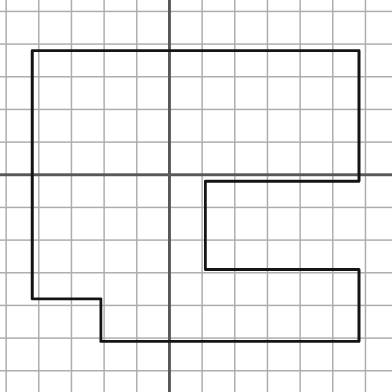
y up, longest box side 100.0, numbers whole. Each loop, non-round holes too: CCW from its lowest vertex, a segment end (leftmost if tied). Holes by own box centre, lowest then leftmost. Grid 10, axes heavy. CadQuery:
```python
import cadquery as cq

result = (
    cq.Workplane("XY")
    .moveTo(-21.0, -51.0)
    .lineTo(58.0, -51.0)
    .lineTo(58.0, -29.0)
    .lineTo(11.0, -29.0)
    .lineTo(11.0, -2.0)
    .lineTo(58.0, -2.0)
    .lineTo(58.0, 38.0)
    .lineTo(-42.0, 38.0)
    .lineTo(-42.0, -38.0)
    .lineTo(-21.0, -38.0)
    .close()
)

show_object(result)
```